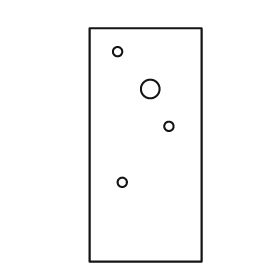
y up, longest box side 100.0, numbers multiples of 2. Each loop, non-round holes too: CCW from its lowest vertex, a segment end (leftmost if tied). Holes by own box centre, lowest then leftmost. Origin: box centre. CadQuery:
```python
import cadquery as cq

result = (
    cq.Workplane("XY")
    .moveTo(-24.0, -50.0)
    .lineTo(24.0, -50.0)
    .lineTo(24.0, 50.0)
    .lineTo(-24.0, 50.0)
    .close()
    .moveTo(-10.0, -16.0)
    .circle(2.0)
    .moveTo(10.0, 8.0)
    .circle(2.0)
    .moveTo(2.0, 24.0)
    .circle(4.0)
    .moveTo(-12.0, 40.0)
    .circle(2.0)
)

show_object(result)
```